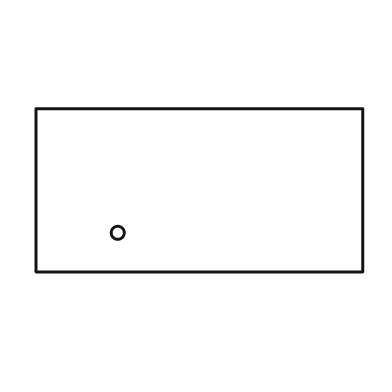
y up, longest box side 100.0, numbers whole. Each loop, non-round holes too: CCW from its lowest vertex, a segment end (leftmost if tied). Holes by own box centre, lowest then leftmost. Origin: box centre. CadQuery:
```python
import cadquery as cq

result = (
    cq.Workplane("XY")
    .moveTo(-50.0, -25.0)
    .lineTo(50.0, -25.0)
    .lineTo(50.0, 25.0)
    .lineTo(-50.0, 25.0)
    .close()
    .moveTo(-25.0, -13.0)
    .circle(2.0)
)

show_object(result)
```